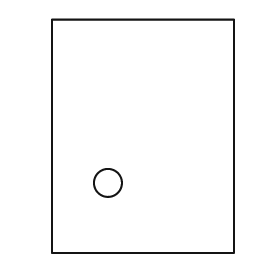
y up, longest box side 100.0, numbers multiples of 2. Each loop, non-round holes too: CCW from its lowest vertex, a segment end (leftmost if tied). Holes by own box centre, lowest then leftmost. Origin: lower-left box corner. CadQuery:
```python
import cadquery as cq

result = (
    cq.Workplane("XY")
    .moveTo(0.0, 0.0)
    .lineTo(78.0, 0.0)
    .lineTo(78.0, 100.0)
    .lineTo(0.0, 100.0)
    .close()
    .moveTo(24.0, 30.0)
    .circle(6.0)
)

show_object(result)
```